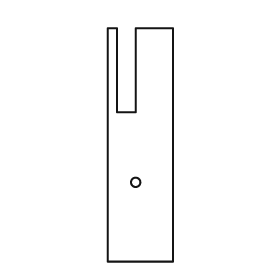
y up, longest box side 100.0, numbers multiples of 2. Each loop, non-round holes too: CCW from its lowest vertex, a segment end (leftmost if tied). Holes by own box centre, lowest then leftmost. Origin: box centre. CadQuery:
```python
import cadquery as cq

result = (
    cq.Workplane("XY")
    .moveTo(-14.0, -50.0)
    .lineTo(14.0, -50.0)
    .lineTo(14.0, 50.0)
    .lineTo(-2.0, 50.0)
    .lineTo(-2.0, 14.0)
    .lineTo(-10.0, 14.0)
    .lineTo(-10.0, 50.0)
    .lineTo(-14.0, 50.0)
    .close()
    .moveTo(-2.0, -16.0)
    .circle(2.0)
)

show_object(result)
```